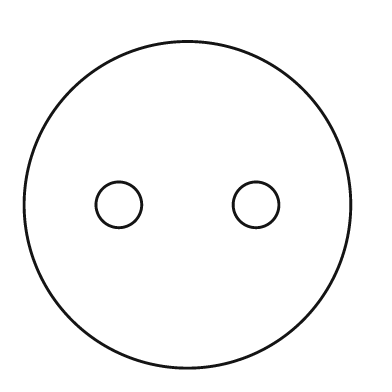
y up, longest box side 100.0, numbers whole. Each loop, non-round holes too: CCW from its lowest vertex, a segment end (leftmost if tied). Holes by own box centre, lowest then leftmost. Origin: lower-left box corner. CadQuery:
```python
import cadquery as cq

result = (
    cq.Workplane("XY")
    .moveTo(50.0, 50.0)
    .circle(50.0)
    .moveTo(29.0, 50.0)
    .circle(7.0)
    .moveTo(71.0, 50.0)
    .circle(7.0)
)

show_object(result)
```